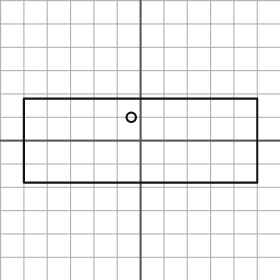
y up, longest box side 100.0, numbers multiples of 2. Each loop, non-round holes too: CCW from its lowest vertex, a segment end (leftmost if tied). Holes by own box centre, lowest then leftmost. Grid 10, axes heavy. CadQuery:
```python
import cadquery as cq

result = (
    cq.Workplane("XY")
    .moveTo(-50.0, -18.0)
    .lineTo(50.0, -18.0)
    .lineTo(50.0, 18.0)
    .lineTo(-50.0, 18.0)
    .close()
    .moveTo(-4.0, 10.0)
    .circle(2.0)
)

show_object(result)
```